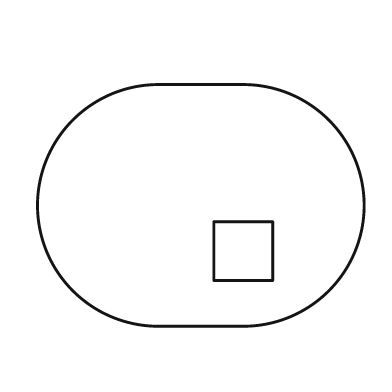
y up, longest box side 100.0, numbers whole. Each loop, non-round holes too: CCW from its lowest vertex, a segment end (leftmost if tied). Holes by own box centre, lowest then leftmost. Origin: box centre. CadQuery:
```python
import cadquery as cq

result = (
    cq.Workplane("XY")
    .moveTo(-13.0, -37.0)
    .lineTo(13.0, -37.0)
    .threePointArc((50.0, 0.0), (13.0, 37.0))
    .lineTo(-13.0, 37.0)
    .threePointArc((-50.0, 0.0), (-13.0, -37.0))
    .close()
    .moveTo(4.0, -23.0)
    .lineTo(22.0, -23.0)
    .lineTo(22.0, -5.0)
    .lineTo(4.0, -5.0)
    .close()
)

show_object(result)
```